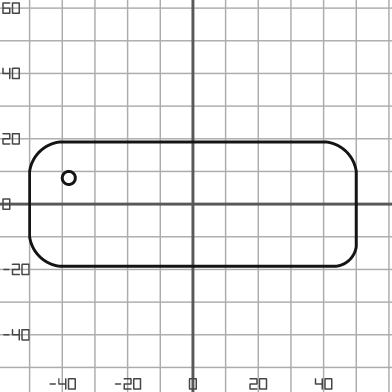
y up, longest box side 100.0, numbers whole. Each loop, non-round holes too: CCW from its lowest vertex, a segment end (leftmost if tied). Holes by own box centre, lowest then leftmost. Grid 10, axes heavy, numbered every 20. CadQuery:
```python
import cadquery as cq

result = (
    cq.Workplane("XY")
    .moveTo(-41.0, -19.0)
    .lineTo(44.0, -19.0)
    .threePointArc((48.0, -17.0), (50.0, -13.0))
    .lineTo(50.0, 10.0)
    .threePointArc((47.0, 16.0), (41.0, 19.0))
    .lineTo(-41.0, 19.0)
    .threePointArc((-47.0, 16.0), (-50.0, 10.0))
    .lineTo(-50.0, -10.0)
    .threePointArc((-47.0, -16.0), (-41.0, -19.0))
    .close()
    .moveTo(-38.0, 8.0)
    .circle(2.0)
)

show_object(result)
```